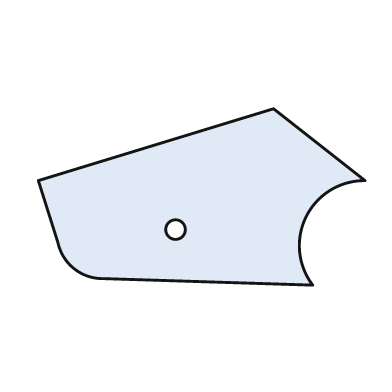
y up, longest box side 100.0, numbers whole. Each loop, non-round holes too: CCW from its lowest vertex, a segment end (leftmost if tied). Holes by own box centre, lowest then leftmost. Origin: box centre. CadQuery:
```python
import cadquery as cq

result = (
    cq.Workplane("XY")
    .moveTo(34.0, -27.0)
    .threePointArc((32.0, -6.0), (50.0, 5.0))
    .lineTo(22.0, 27.0)
    .lineTo(-50.0, 5.0)
    .lineTo(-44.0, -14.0)
    .threePointArc((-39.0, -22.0), (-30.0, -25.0))
    .close()
    .moveTo(-8.0, -10.0)
    .circle(3.0)
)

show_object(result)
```